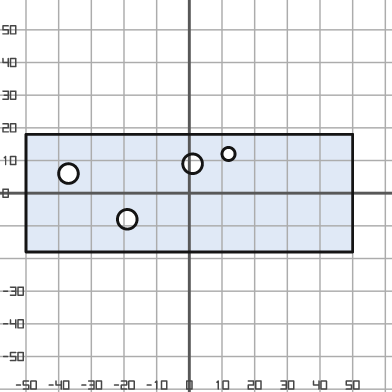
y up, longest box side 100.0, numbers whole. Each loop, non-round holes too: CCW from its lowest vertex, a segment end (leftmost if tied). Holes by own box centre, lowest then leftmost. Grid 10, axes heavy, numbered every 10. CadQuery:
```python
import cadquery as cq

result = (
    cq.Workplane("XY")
    .moveTo(-50.0, -18.0)
    .lineTo(50.0, -18.0)
    .lineTo(50.0, 18.0)
    .lineTo(-50.0, 18.0)
    .close()
    .moveTo(-19.0, -8.0)
    .circle(3.0)
    .moveTo(-37.0, 6.0)
    .circle(3.0)
    .moveTo(1.0, 9.0)
    .circle(3.0)
    .moveTo(12.0, 12.0)
    .circle(2.0)
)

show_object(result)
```